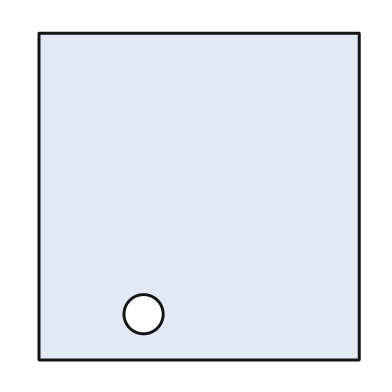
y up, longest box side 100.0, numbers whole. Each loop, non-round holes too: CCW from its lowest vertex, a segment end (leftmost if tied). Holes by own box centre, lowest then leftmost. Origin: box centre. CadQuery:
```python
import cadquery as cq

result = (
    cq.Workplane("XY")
    .moveTo(-49.0, -50.0)
    .lineTo(49.0, -50.0)
    .lineTo(49.0, 50.0)
    .lineTo(-49.0, 50.0)
    .close()
    .moveTo(-17.0, -36.0)
    .circle(6.0)
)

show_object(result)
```